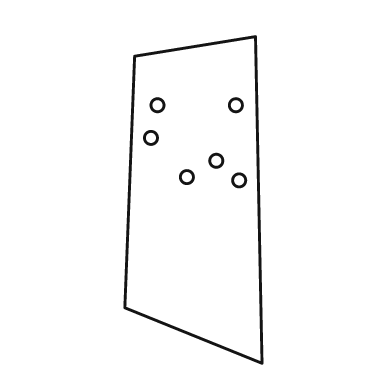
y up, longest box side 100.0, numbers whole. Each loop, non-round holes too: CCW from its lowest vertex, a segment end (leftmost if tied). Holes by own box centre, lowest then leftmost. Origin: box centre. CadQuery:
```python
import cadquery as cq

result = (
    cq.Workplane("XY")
    .moveTo(21.0, -50.0)
    .lineTo(19.0, 50.0)
    .lineTo(-18.0, 44.0)
    .lineTo(-21.0, -33.0)
    .close()
    .moveTo(14.0, 6.0)
    .circle(2.0)
    .moveTo(-2.0, 7.0)
    .circle(2.0)
    .moveTo(7.0, 12.0)
    .circle(2.0)
    .moveTo(-13.0, 19.0)
    .circle(2.0)
    .moveTo(-11.0, 29.0)
    .circle(2.0)
    .moveTo(13.0, 29.0)
    .circle(2.0)
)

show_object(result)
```